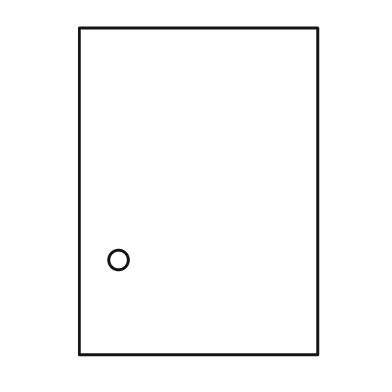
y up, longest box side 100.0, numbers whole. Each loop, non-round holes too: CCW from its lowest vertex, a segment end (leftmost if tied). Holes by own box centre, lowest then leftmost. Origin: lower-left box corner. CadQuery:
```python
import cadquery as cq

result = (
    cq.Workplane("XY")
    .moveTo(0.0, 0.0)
    .lineTo(73.0, 0.0)
    .lineTo(73.0, 100.0)
    .lineTo(0.0, 100.0)
    .close()
    .moveTo(12.0, 29.0)
    .circle(3.0)
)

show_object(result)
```